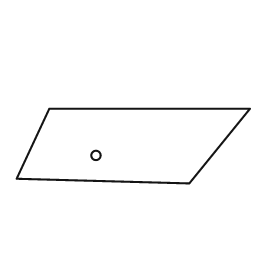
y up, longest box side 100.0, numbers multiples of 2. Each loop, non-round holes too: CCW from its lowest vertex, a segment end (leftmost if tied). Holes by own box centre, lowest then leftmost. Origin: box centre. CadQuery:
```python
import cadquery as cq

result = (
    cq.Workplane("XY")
    .moveTo(24.0, -16.0)
    .lineTo(50.0, 16.0)
    .lineTo(-36.0, 16.0)
    .lineTo(-50.0, -14.0)
    .close()
    .moveTo(-16.0, -4.0)
    .circle(2.0)
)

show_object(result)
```